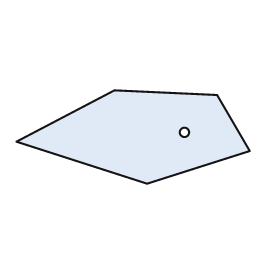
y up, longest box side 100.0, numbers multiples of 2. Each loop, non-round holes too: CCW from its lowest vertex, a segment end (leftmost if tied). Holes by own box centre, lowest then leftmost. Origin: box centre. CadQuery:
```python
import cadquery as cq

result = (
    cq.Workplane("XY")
    .moveTo(6.0, -20.0)
    .lineTo(50.0, -6.0)
    .lineTo(36.0, 18.0)
    .lineTo(-8.0, 20.0)
    .lineTo(-50.0, -2.0)
    .close()
    .moveTo(22.0, 2.0)
    .circle(2.0)
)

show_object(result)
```